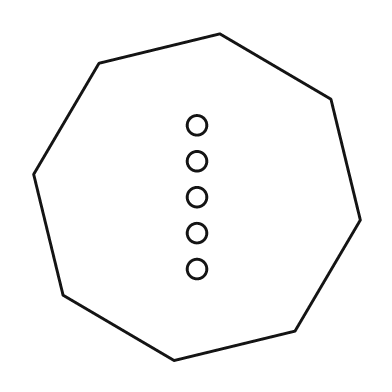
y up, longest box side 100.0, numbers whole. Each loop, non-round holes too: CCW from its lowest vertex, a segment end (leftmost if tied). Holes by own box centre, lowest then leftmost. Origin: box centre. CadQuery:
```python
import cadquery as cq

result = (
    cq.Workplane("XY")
    .moveTo(-7.0, -50.0)
    .lineTo(30.0, -41.0)
    .lineTo(50.0, -7.0)
    .lineTo(41.0, 30.0)
    .lineTo(7.0, 50.0)
    .lineTo(-30.0, 41.0)
    .lineTo(-50.0, 7.0)
    .lineTo(-41.0, -30.0)
    .close()
    .moveTo(0.0, -22.0)
    .circle(3.0)
    .moveTo(0.0, -11.0)
    .circle(3.0)
    .moveTo(0.0, 0.0)
    .circle(3.0)
    .moveTo(0.0, 11.0)
    .circle(3.0)
    .moveTo(0.0, 22.0)
    .circle(3.0)
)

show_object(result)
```